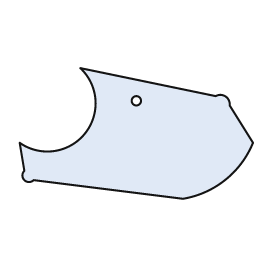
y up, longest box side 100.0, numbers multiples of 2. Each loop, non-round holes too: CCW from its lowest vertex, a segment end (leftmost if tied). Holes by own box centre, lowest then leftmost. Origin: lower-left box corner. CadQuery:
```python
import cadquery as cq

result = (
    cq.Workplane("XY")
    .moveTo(70.0, 0.0)
    .threePointArc((88.0, 8.0), (100.0, 24.0))
    .lineTo(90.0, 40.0)
    .threePointArc((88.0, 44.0), (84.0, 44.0))
    .lineTo(26.0, 56.0)
    .threePointArc((28.0, 28.0), (0.0, 24.0))
    .lineTo(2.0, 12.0)
    .threePointArc((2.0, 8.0), (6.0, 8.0))
    .close()
    .moveTo(50.0, 42.0)
    .circle(2.0)
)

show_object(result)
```